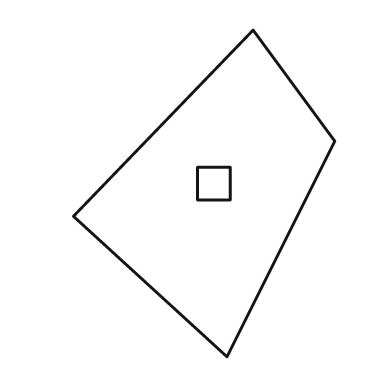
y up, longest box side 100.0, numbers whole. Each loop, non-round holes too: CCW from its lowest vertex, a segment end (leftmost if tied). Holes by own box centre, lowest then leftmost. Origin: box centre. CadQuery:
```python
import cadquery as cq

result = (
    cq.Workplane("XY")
    .moveTo(7.0, -50.0)
    .lineTo(40.0, 16.0)
    .lineTo(15.0, 50.0)
    .lineTo(-40.0, -7.0)
    .close()
    .moveTo(-2.0, -2.0)
    .lineTo(8.0, -2.0)
    .lineTo(8.0, 8.0)
    .lineTo(-2.0, 8.0)
    .close()
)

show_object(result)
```